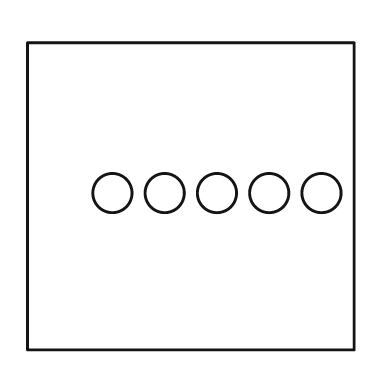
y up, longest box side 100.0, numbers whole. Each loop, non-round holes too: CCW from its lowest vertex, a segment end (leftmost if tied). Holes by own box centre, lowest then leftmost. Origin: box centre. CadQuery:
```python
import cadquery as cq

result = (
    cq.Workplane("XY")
    .moveTo(-50.0, -47.0)
    .lineTo(50.0, -47.0)
    .lineTo(50.0, 47.0)
    .lineTo(-50.0, 47.0)
    .close()
    .moveTo(-24.0, 1.0)
    .circle(6.0)
    .moveTo(-8.0, 1.0)
    .circle(6.0)
    .moveTo(8.0, 1.0)
    .circle(6.0)
    .moveTo(24.0, 1.0)
    .circle(6.0)
    .moveTo(40.0, 1.0)
    .circle(6.0)
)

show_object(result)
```